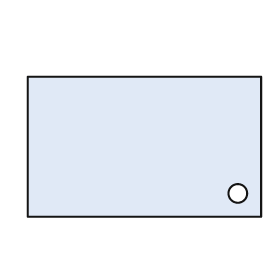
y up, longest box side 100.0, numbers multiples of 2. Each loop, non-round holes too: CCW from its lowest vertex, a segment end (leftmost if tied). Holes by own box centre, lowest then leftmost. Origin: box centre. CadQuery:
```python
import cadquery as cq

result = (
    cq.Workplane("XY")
    .moveTo(-50.0, -30.0)
    .lineTo(50.0, -30.0)
    .lineTo(50.0, 30.0)
    .lineTo(-50.0, 30.0)
    .close()
    .moveTo(40.0, -20.0)
    .circle(4.0)
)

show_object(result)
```